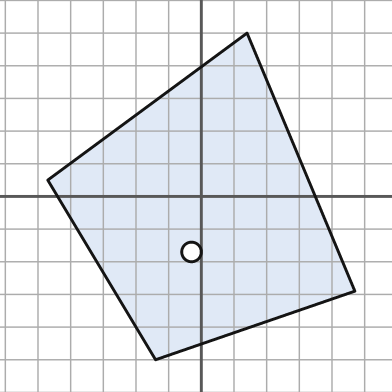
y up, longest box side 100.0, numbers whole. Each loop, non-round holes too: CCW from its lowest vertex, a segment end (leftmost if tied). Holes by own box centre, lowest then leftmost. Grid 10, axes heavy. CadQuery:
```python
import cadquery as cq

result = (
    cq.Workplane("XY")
    .moveTo(-14.0, -50.0)
    .lineTo(47.0, -29.0)
    .lineTo(14.0, 50.0)
    .lineTo(-47.0, 5.0)
    .close()
    .moveTo(-3.0, -17.0)
    .circle(3.0)
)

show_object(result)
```